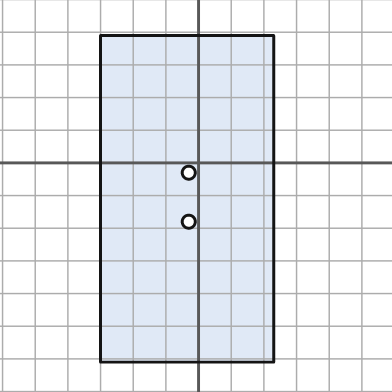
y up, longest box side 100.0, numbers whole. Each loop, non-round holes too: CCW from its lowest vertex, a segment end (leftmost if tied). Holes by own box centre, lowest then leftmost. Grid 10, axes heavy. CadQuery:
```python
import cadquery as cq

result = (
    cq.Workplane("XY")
    .moveTo(-30.0, -61.0)
    .lineTo(23.0, -61.0)
    .lineTo(23.0, 39.0)
    .lineTo(-30.0, 39.0)
    .close()
    .moveTo(-3.0, -18.0)
    .circle(2.0)
    .moveTo(-3.0, -3.0)
    .circle(2.0)
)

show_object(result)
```